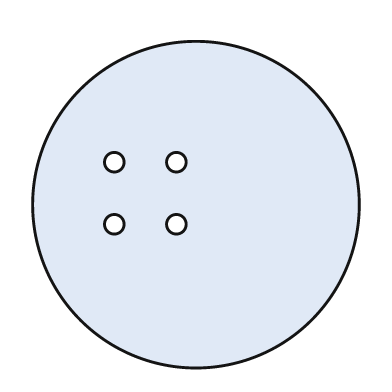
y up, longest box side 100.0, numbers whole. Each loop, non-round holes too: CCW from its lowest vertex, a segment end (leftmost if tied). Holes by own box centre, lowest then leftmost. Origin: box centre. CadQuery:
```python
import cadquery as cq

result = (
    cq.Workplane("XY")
    .moveTo(0.0, 0.0)
    .circle(50.0)
    .moveTo(-25.0, -6.0)
    .circle(3.0)
    .moveTo(-6.0, -6.0)
    .circle(3.0)
    .moveTo(-25.0, 13.0)
    .circle(3.0)
    .moveTo(-6.0, 13.0)
    .circle(3.0)
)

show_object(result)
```